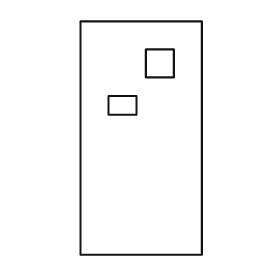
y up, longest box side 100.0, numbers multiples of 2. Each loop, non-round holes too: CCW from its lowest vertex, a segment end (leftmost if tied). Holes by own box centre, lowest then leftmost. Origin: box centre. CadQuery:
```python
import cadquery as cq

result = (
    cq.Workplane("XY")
    .moveTo(-26.0, -50.0)
    .lineTo(26.0, -50.0)
    .lineTo(26.0, 50.0)
    .lineTo(-26.0, 50.0)
    .close()
    .moveTo(-14.0, 10.0)
    .lineTo(-2.0, 10.0)
    .lineTo(-2.0, 18.0)
    .lineTo(-14.0, 18.0)
    .close()
    .moveTo(2.0, 26.0)
    .lineTo(14.0, 26.0)
    .lineTo(14.0, 38.0)
    .lineTo(2.0, 38.0)
    .close()
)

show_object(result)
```